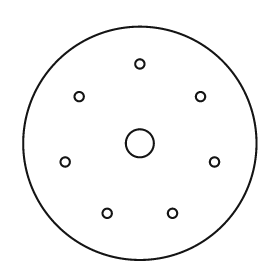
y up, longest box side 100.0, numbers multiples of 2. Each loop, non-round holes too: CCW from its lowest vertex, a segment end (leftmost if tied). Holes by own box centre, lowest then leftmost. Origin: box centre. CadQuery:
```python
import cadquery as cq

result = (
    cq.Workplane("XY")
    .moveTo(0.0, 0.0)
    .circle(50.0)
    .moveTo(-14.0, -30.0)
    .circle(2.0)
    .moveTo(14.0, -30.0)
    .circle(2.0)
    .moveTo(-32.0, -8.0)
    .circle(2.0)
    .moveTo(32.0, -8.0)
    .circle(2.0)
    .moveTo(0.0, 0.0)
    .circle(6.0)
    .moveTo(-26.0, 20.0)
    .circle(2.0)
    .moveTo(26.0, 20.0)
    .circle(2.0)
    .moveTo(0.0, 34.0)
    .circle(2.0)
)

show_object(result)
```